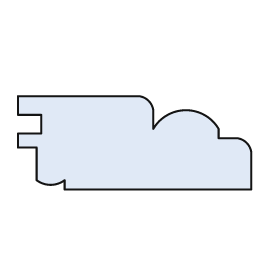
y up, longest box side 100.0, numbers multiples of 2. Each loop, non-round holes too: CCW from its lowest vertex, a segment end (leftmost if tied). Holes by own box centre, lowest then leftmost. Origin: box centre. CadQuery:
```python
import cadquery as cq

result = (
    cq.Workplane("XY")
    .moveTo(-30.0, -20.0)
    .lineTo(50.0, -20.0)
    .lineTo(50.0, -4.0)
    .threePointArc((48.0, 0.0), (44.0, 2.0))
    .lineTo(36.0, 2.0)
    .lineTo(36.0, 6.0)
    .threePointArc((22.0, 14.0), (8.0, 6.0))
    .lineTo(8.0, 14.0)
    .threePointArc((6.0, 18.0), (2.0, 20.0))
    .lineTo(-50.0, 20.0)
    .lineTo(-50.0, 12.0)
    .lineTo(-40.0, 12.0)
    .lineTo(-40.0, 4.0)
    .lineTo(-50.0, 4.0)
    .lineTo(-50.0, -2.0)
    .lineTo(-42.0, -2.0)
    .lineTo(-42.0, -16.0)
    .threePointArc((-36.0, -18.0), (-30.0, -16.0))
    .close()
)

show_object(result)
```